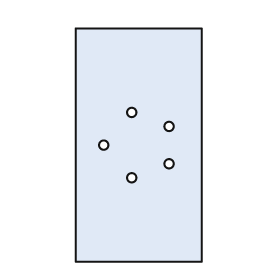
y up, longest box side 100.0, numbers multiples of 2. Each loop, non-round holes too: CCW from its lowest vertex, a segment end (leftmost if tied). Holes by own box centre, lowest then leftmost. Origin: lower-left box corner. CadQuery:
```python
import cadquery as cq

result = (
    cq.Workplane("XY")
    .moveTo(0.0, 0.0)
    .lineTo(54.0, 0.0)
    .lineTo(54.0, 100.0)
    .lineTo(0.0, 100.0)
    .close()
    .moveTo(24.0, 36.0)
    .circle(2.0)
    .moveTo(40.0, 42.0)
    .circle(2.0)
    .moveTo(12.0, 50.0)
    .circle(2.0)
    .moveTo(40.0, 58.0)
    .circle(2.0)
    .moveTo(24.0, 64.0)
    .circle(2.0)
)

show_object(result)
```